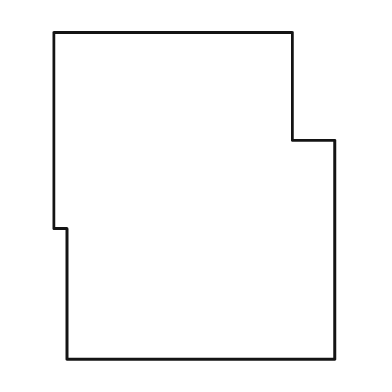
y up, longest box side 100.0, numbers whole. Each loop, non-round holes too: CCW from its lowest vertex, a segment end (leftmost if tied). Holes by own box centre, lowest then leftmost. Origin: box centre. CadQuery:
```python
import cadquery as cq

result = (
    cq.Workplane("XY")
    .moveTo(-39.0, -50.0)
    .lineTo(43.0, -50.0)
    .lineTo(43.0, 17.0)
    .lineTo(30.0, 17.0)
    .lineTo(30.0, 50.0)
    .lineTo(-43.0, 50.0)
    .lineTo(-43.0, -10.0)
    .lineTo(-39.0, -10.0)
    .close()
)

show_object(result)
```